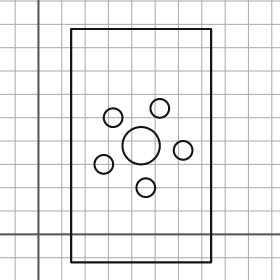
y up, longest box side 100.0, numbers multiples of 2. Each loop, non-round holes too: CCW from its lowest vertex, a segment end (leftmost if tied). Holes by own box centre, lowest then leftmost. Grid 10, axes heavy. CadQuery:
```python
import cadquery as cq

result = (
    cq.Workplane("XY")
    .moveTo(14.0, -12.0)
    .lineTo(74.0, -12.0)
    .lineTo(74.0, 88.0)
    .lineTo(14.0, 88.0)
    .close()
    .moveTo(46.0, 20.0)
    .circle(4.0)
    .moveTo(28.0, 30.0)
    .circle(4.0)
    .moveTo(62.0, 36.0)
    .circle(4.0)
    .moveTo(44.0, 38.0)
    .circle(8.0)
    .moveTo(32.0, 50.0)
    .circle(4.0)
    .moveTo(52.0, 54.0)
    .circle(4.0)
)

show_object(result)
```